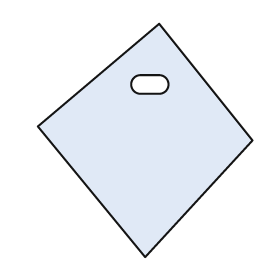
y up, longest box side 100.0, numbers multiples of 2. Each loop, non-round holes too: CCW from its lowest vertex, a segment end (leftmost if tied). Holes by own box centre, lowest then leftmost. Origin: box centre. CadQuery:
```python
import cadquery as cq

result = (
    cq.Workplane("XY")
    .moveTo(0.0, -50.0)
    .lineTo(46.0, 0.0)
    .lineTo(6.0, 50.0)
    .lineTo(-46.0, 6.0)
    .close()
    .moveTo(-2.0, 20.0)
    .lineTo(6.0, 20.0)
    .threePointArc((10.0, 24.0), (6.0, 28.0))
    .lineTo(-2.0, 28.0)
    .threePointArc((-6.0, 24.0), (-2.0, 20.0))
    .close()
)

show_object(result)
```